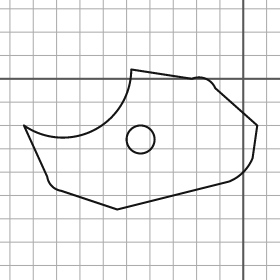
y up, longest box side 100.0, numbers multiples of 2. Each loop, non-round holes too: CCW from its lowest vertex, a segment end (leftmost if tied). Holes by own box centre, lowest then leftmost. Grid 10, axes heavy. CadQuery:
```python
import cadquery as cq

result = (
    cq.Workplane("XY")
    .moveTo(-54.0, -56.0)
    .lineTo(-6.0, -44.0)
    .threePointArc((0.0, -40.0), (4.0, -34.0))
    .lineTo(6.0, -20.0)
    .lineTo(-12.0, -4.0)
    .threePointArc((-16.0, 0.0), (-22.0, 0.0))
    .lineTo(-48.0, 4.0)
    .threePointArc((-64.0, -22.0), (-94.0, -20.0))
    .lineTo(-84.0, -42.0)
    .threePointArc((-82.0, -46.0), (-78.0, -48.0))
    .close()
    .moveTo(-44.0, -26.0)
    .circle(6.0)
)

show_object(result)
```